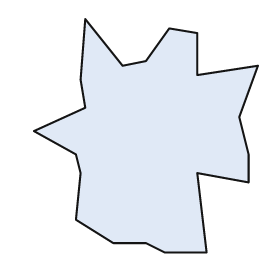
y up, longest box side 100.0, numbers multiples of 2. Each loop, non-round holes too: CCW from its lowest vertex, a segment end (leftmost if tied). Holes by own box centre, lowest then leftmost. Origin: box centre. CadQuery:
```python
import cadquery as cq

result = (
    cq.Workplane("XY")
    .moveTo(8.0, -50.0)
    .lineTo(26.0, -50.0)
    .lineTo(22.0, -16.0)
    .lineTo(44.0, -20.0)
    .lineTo(44.0, -8.0)
    .lineTo(40.0, 8.0)
    .lineTo(48.0, 30.0)
    .lineTo(22.0, 26.0)
    .lineTo(22.0, 44.0)
    .lineTo(10.0, 46.0)
    .lineTo(0.0, 32.0)
    .lineTo(-10.0, 30.0)
    .lineTo(-26.0, 50.0)
    .lineTo(-28.0, 24.0)
    .lineTo(-26.0, 12.0)
    .lineTo(-48.0, 2.0)
    .lineTo(-30.0, -8.0)
    .lineTo(-28.0, -16.0)
    .lineTo(-30.0, -36.0)
    .lineTo(-14.0, -46.0)
    .lineTo(0.0, -46.0)
    .close()
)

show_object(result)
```